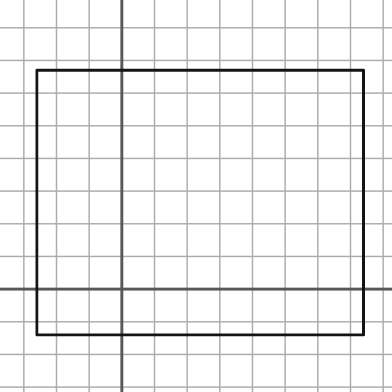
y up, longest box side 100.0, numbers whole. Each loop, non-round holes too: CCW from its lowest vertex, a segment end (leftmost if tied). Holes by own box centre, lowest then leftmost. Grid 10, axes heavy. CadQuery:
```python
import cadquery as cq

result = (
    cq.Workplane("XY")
    .moveTo(-26.0, -14.0)
    .lineTo(74.0, -14.0)
    .lineTo(74.0, 67.0)
    .lineTo(-26.0, 67.0)
    .close()
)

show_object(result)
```